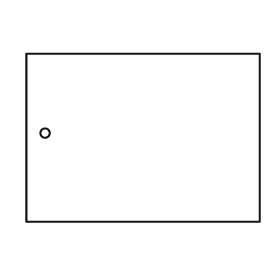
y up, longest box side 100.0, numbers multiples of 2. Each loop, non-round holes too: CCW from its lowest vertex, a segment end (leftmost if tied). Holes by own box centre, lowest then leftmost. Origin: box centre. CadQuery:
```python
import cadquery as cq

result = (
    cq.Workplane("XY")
    .moveTo(-50.0, -36.0)
    .lineTo(50.0, -36.0)
    .lineTo(50.0, 36.0)
    .lineTo(-50.0, 36.0)
    .close()
    .moveTo(-42.0, 2.0)
    .circle(2.0)
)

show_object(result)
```